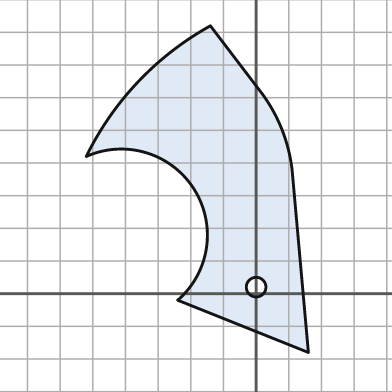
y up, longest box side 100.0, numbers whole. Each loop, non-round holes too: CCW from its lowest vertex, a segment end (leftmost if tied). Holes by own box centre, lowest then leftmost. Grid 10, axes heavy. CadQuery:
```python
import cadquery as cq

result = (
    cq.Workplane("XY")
    .moveTo(16.0, -18.0)
    .lineTo(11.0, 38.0)
    .threePointArc((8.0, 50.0), (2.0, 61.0))
    .lineTo(-14.0, 82.0)
    .threePointArc((-36.0, 65.0), (-52.0, 42.0))
    .threePointArc((-19.0, 32.0), (-24.0, -2.0))
    .close()
    .moveTo(0.0, 2.0)
    .circle(3.0)
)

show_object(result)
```